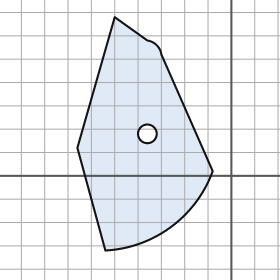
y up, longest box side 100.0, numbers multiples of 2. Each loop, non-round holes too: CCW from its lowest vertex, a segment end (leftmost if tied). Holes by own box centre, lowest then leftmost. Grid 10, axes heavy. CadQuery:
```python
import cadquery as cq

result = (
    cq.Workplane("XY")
    .moveTo(-54.0, -32.0)
    .threePointArc((-26.0, -22.0), (-8.0, 2.0))
    .lineTo(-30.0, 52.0)
    .threePointArc((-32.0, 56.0), (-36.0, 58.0))
    .lineTo(-50.0, 68.0)
    .lineTo(-66.0, 12.0)
    .close()
    .moveTo(-36.0, 18.0)
    .circle(4.0)
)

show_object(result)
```